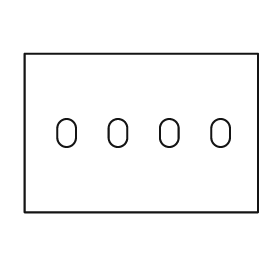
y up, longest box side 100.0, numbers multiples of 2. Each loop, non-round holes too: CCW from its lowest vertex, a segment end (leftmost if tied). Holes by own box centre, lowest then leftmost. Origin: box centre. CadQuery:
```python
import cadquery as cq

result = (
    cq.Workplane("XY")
    .moveTo(-50.0, -34.0)
    .lineTo(50.0, -34.0)
    .lineTo(50.0, 34.0)
    .lineTo(-50.0, 34.0)
    .close()
    .moveTo(-36.0, -2.0)
    .threePointArc((-32.0, -6.0), (-28.0, -2.0))
    .lineTo(-28.0, 2.0)
    .threePointArc((-32.0, 6.0), (-36.0, 2.0))
    .close()
    .moveTo(-14.0, -2.0)
    .threePointArc((-10.0, -6.0), (-6.0, -2.0))
    .lineTo(-6.0, 2.0)
    .threePointArc((-10.0, 6.0), (-14.0, 2.0))
    .close()
    .moveTo(8.0, -2.0)
    .threePointArc((12.0, -6.0), (16.0, -2.0))
    .lineTo(16.0, 2.0)
    .threePointArc((12.0, 6.0), (8.0, 2.0))
    .close()
    .moveTo(30.0, -2.0)
    .threePointArc((34.0, -6.0), (38.0, -2.0))
    .lineTo(38.0, 2.0)
    .threePointArc((34.0, 6.0), (30.0, 2.0))
    .close()
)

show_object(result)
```